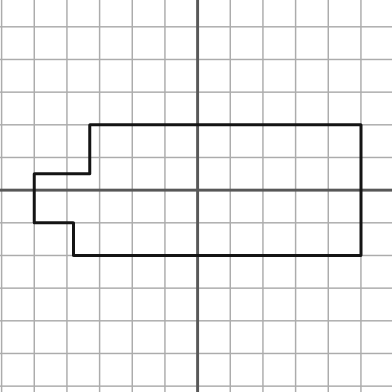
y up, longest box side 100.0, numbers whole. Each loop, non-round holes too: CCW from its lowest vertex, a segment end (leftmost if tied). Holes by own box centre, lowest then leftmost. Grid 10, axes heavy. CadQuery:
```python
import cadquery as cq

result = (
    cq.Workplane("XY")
    .moveTo(-38.0, -20.0)
    .lineTo(50.0, -20.0)
    .lineTo(50.0, 20.0)
    .lineTo(-33.0, 20.0)
    .lineTo(-33.0, 5.0)
    .lineTo(-50.0, 5.0)
    .lineTo(-50.0, -10.0)
    .lineTo(-38.0, -10.0)
    .close()
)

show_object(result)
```